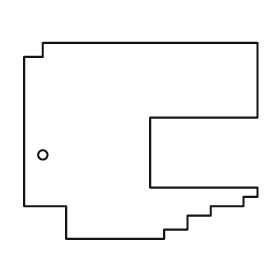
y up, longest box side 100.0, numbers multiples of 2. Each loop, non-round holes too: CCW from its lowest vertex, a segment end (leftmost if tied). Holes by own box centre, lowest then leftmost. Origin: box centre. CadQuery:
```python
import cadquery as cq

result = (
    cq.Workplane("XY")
    .moveTo(-32.0, -42.0)
    .lineTo(10.0, -42.0)
    .lineTo(10.0, -38.0)
    .lineTo(20.0, -38.0)
    .lineTo(20.0, -32.0)
    .lineTo(30.0, -32.0)
    .lineTo(30.0, -28.0)
    .lineTo(44.0, -28.0)
    .lineTo(44.0, -24.0)
    .lineTo(50.0, -24.0)
    .lineTo(50.0, -20.0)
    .lineTo(4.0, -20.0)
    .lineTo(4.0, 10.0)
    .lineTo(50.0, 10.0)
    .lineTo(50.0, 42.0)
    .lineTo(-42.0, 42.0)
    .lineTo(-42.0, 36.0)
    .lineTo(-50.0, 36.0)
    .lineTo(-50.0, -28.0)
    .lineTo(-32.0, -28.0)
    .close()
    .moveTo(-42.0, -6.0)
    .circle(2.0)
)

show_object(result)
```